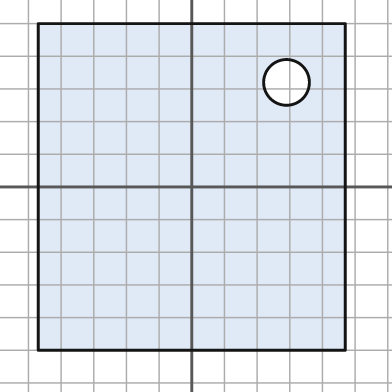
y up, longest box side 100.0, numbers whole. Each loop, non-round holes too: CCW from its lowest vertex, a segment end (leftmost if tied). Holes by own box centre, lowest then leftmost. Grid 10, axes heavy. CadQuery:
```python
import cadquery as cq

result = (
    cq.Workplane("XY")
    .moveTo(-47.0, -50.0)
    .lineTo(47.0, -50.0)
    .lineTo(47.0, 50.0)
    .lineTo(-47.0, 50.0)
    .close()
    .moveTo(29.0, 32.0)
    .circle(7.0)
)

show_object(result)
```